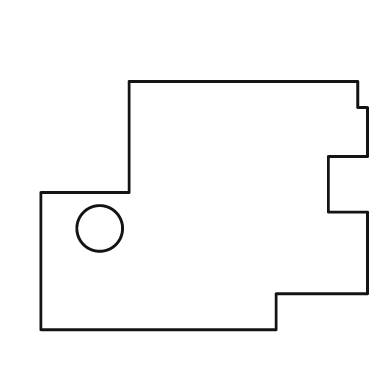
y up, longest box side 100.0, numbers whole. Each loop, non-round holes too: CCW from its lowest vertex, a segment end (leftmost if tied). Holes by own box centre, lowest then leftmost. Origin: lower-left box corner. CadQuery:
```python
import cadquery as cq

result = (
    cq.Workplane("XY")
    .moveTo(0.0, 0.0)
    .lineTo(72.0, 0.0)
    .lineTo(72.0, 11.0)
    .lineTo(100.0, 11.0)
    .lineTo(100.0, 36.0)
    .lineTo(88.0, 36.0)
    .lineTo(88.0, 53.0)
    .lineTo(100.0, 53.0)
    .lineTo(100.0, 68.0)
    .lineTo(97.0, 68.0)
    .lineTo(97.0, 76.0)
    .lineTo(27.0, 76.0)
    .lineTo(27.0, 42.0)
    .lineTo(0.0, 42.0)
    .close()
    .moveTo(18.0, 31.0)
    .circle(7.0)
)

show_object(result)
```